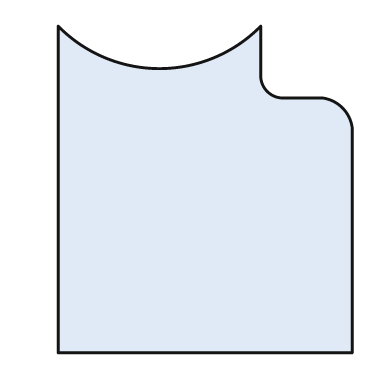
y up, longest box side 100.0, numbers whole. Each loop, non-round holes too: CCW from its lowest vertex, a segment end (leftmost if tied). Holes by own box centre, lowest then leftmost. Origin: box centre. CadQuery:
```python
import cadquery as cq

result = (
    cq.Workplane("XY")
    .moveTo(-45.0, -50.0)
    .lineTo(45.0, -50.0)
    .lineTo(45.0, 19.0)
    .threePointArc((42.0, 25.0), (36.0, 28.0))
    .lineTo(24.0, 28.0)
    .threePointArc((19.0, 30.0), (17.0, 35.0))
    .lineTo(17.0, 50.0)
    .threePointArc((-14.0, 37.0), (-45.0, 50.0))
    .close()
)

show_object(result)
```